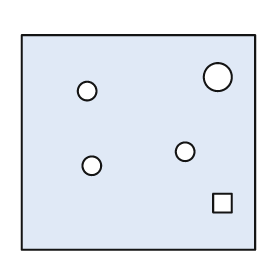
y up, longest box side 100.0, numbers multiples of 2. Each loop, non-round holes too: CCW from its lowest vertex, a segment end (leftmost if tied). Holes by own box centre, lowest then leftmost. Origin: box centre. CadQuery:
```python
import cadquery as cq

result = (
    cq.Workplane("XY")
    .moveTo(-50.0, -46.0)
    .lineTo(50.0, -46.0)
    .lineTo(50.0, 46.0)
    .lineTo(-50.0, 46.0)
    .close()
    .moveTo(32.0, -30.0)
    .lineTo(40.0, -30.0)
    .lineTo(40.0, -22.0)
    .lineTo(32.0, -22.0)
    .close()
    .moveTo(-20.0, -10.0)
    .circle(4.0)
    .moveTo(20.0, -4.0)
    .circle(4.0)
    .moveTo(-22.0, 22.0)
    .circle(4.0)
    .moveTo(34.0, 28.0)
    .circle(6.0)
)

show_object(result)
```